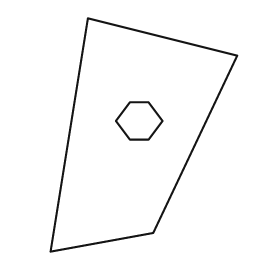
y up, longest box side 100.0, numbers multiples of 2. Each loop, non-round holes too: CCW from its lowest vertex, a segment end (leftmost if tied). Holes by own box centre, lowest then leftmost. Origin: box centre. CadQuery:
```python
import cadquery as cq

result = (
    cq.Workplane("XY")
    .moveTo(-40.0, -50.0)
    .lineTo(4.0, -42.0)
    .lineTo(40.0, 34.0)
    .lineTo(-24.0, 50.0)
    .close()
    .moveTo(-6.0, -2.0)
    .lineTo(2.0, -2.0)
    .lineTo(8.0, 6.0)
    .lineTo(2.0, 14.0)
    .lineTo(-6.0, 14.0)
    .lineTo(-12.0, 6.0)
    .close()
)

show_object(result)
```